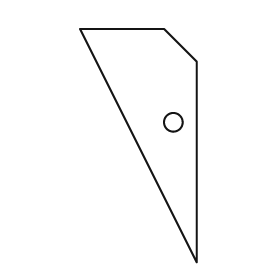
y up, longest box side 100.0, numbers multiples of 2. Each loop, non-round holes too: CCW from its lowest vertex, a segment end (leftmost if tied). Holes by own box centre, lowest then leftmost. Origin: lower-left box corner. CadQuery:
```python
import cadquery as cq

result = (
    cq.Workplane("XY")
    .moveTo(50.0, 0.0)
    .lineTo(50.0, 86.0)
    .lineTo(36.0, 100.0)
    .lineTo(0.0, 100.0)
    .close()
    .moveTo(40.0, 60.0)
    .circle(4.0)
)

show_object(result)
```